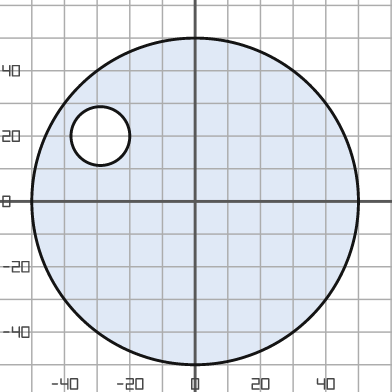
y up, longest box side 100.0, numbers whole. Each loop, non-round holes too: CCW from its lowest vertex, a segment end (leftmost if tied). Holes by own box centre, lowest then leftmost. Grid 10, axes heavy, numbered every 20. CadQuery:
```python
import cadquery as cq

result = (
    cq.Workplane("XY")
    .moveTo(0.0, 0.0)
    .circle(50.0)
    .moveTo(-29.0, 20.0)
    .circle(9.0)
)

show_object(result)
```